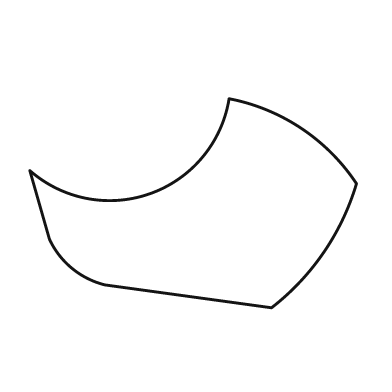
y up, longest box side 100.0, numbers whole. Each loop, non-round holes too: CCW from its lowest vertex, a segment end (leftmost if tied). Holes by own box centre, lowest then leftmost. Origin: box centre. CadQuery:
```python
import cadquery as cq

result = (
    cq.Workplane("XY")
    .moveTo(24.0, -32.0)
    .threePointArc((40.0, -15.0), (50.0, 6.0))
    .threePointArc((33.0, 23.0), (11.0, 32.0))
    .threePointArc((-13.0, 3.0), (-50.0, 10.0))
    .lineTo(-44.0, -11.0)
    .threePointArc((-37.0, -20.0), (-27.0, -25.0))
    .close()
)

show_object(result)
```